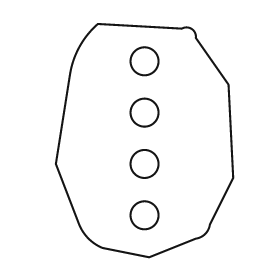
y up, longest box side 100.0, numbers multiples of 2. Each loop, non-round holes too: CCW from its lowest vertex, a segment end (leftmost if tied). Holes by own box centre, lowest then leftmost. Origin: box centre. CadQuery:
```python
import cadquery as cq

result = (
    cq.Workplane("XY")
    .moveTo(2.0, -50.0)
    .lineTo(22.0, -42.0)
    .threePointArc((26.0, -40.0), (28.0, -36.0))
    .lineTo(38.0, -16.0)
    .lineTo(36.0, 24.0)
    .lineTo(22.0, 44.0)
    .threePointArc((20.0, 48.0), (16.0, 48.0))
    .lineTo(-20.0, 50.0)
    .threePointArc((-28.0, 40.0), (-32.0, 28.0))
    .lineTo(-38.0, -10.0)
    .lineTo(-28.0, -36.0)
    .threePointArc((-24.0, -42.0), (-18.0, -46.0))
    .close()
    .moveTo(0.0, -32.0)
    .circle(6.0)
    .moveTo(0.0, -10.0)
    .circle(6.0)
    .moveTo(0.0, 12.0)
    .circle(6.0)
    .moveTo(0.0, 34.0)
    .circle(6.0)
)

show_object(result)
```